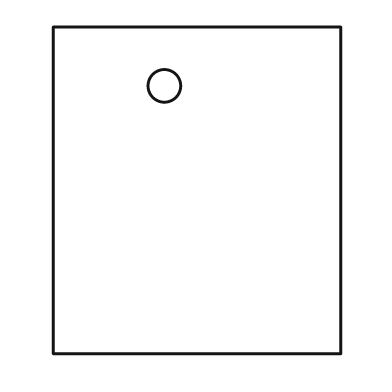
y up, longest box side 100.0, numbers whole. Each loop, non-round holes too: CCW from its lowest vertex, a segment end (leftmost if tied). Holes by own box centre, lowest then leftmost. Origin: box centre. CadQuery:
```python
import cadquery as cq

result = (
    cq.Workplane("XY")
    .moveTo(-44.0, -50.0)
    .lineTo(44.0, -50.0)
    .lineTo(44.0, 50.0)
    .lineTo(-44.0, 50.0)
    .close()
    .moveTo(-10.0, 32.0)
    .circle(5.0)
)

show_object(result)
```